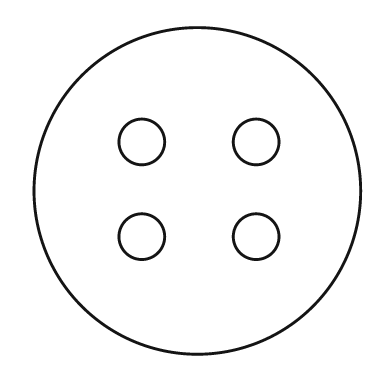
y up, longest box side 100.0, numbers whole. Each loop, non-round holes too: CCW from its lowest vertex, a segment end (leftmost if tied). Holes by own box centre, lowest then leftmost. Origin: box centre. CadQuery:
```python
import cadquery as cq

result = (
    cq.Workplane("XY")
    .moveTo(0.0, 0.0)
    .circle(50.0)
    .moveTo(-17.0, -14.0)
    .circle(7.0)
    .moveTo(18.0, -14.0)
    .circle(7.0)
    .moveTo(-17.0, 15.0)
    .circle(7.0)
    .moveTo(18.0, 15.0)
    .circle(7.0)
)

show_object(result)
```